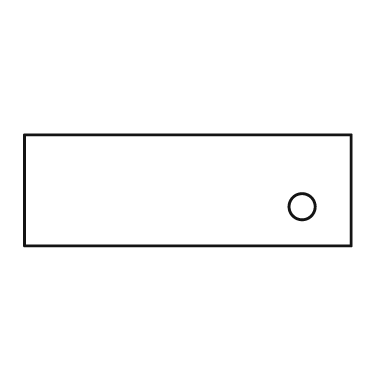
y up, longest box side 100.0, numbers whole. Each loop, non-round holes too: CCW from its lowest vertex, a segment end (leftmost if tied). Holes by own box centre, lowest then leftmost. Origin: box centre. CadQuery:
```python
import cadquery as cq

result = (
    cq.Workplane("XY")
    .moveTo(-50.0, -17.0)
    .lineTo(50.0, -17.0)
    .lineTo(50.0, 17.0)
    .lineTo(-50.0, 17.0)
    .close()
    .moveTo(35.0, -5.0)
    .circle(4.0)
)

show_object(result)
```